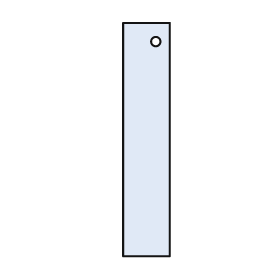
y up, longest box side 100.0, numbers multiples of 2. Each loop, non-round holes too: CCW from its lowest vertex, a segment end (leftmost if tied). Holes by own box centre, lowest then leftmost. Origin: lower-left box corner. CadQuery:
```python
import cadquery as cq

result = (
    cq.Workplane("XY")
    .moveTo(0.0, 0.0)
    .lineTo(20.0, 0.0)
    .lineTo(20.0, 100.0)
    .lineTo(0.0, 100.0)
    .close()
    .moveTo(14.0, 92.0)
    .circle(2.0)
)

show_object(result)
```